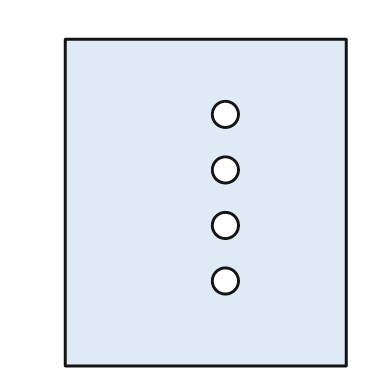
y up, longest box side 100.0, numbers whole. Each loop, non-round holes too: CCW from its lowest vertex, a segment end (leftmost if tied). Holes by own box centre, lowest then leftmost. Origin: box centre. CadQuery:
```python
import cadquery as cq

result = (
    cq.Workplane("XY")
    .moveTo(-43.0, -50.0)
    .lineTo(43.0, -50.0)
    .lineTo(43.0, 50.0)
    .lineTo(-43.0, 50.0)
    .close()
    .moveTo(6.0, -24.0)
    .circle(4.0)
    .moveTo(6.0, -7.0)
    .circle(4.0)
    .moveTo(6.0, 10.0)
    .circle(4.0)
    .moveTo(6.0, 27.0)
    .circle(4.0)
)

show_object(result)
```